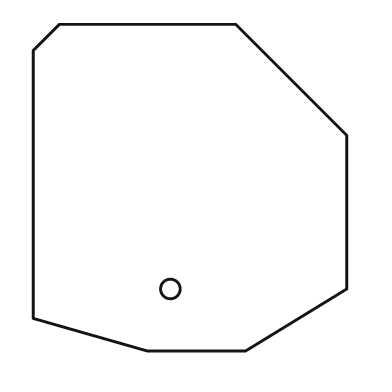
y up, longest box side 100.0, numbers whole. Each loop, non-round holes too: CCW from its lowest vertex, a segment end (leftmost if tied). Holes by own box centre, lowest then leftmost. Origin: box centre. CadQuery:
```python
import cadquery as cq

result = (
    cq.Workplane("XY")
    .moveTo(-13.0, -50.0)
    .lineTo(17.0, -50.0)
    .lineTo(48.0, -31.0)
    .lineTo(48.0, 16.0)
    .lineTo(14.0, 50.0)
    .lineTo(-40.0, 50.0)
    .lineTo(-48.0, 42.0)
    .lineTo(-48.0, -40.0)
    .close()
    .moveTo(-6.0, -31.0)
    .circle(3.0)
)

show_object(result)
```